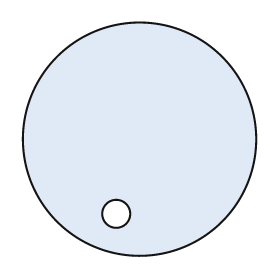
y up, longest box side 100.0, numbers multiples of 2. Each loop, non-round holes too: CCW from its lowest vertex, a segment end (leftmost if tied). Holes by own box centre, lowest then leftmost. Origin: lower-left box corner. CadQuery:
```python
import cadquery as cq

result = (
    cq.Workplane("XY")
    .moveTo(50.0, 50.0)
    .circle(50.0)
    .moveTo(40.0, 18.0)
    .circle(6.0)
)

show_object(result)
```